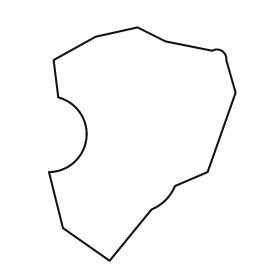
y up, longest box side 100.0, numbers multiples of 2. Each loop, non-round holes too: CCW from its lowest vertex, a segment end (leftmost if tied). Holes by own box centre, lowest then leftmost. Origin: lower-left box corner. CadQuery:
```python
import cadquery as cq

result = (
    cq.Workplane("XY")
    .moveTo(26.0, 0.0)
    .lineTo(44.0, 22.0)
    .threePointArc((50.0, 26.0), (54.0, 32.0))
    .lineTo(68.0, 38.0)
    .lineTo(80.0, 72.0)
    .lineTo(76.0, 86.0)
    .threePointArc((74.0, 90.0), (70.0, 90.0))
    .lineTo(50.0, 94.0)
    .lineTo(38.0, 100.0)
    .lineTo(20.0, 96.0)
    .lineTo(2.0, 86.0)
    .lineTo(4.0, 70.0)
    .threePointArc((16.0, 52.0), (0.0, 38.0))
    .lineTo(6.0, 14.0)
    .close()
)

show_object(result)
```